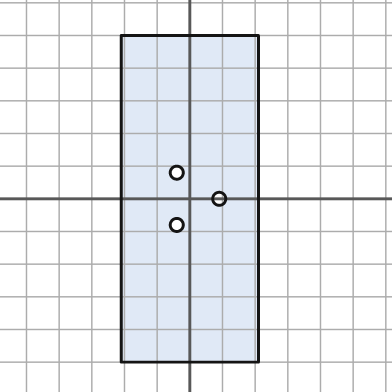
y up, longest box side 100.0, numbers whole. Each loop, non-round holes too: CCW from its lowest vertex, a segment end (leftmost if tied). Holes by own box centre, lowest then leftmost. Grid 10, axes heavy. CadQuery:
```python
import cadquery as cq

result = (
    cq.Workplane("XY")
    .moveTo(-21.0, -50.0)
    .lineTo(21.0, -50.0)
    .lineTo(21.0, 50.0)
    .lineTo(-21.0, 50.0)
    .close()
    .moveTo(-4.0, -8.0)
    .circle(2.0)
    .moveTo(9.0, 0.0)
    .circle(2.0)
    .moveTo(-4.0, 8.0)
    .circle(2.0)
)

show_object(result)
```